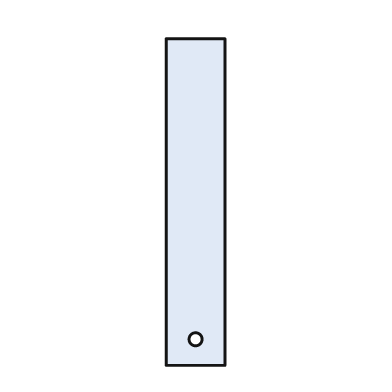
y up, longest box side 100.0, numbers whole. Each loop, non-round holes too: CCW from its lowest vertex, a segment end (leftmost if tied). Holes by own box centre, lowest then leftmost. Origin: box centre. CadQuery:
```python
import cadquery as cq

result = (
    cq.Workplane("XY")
    .moveTo(-9.0, -50.0)
    .lineTo(9.0, -50.0)
    .lineTo(9.0, 50.0)
    .lineTo(-9.0, 50.0)
    .close()
    .moveTo(0.0, -42.0)
    .circle(2.0)
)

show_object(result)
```